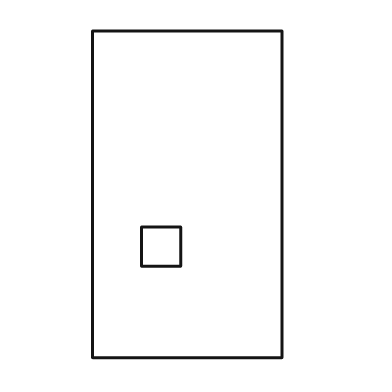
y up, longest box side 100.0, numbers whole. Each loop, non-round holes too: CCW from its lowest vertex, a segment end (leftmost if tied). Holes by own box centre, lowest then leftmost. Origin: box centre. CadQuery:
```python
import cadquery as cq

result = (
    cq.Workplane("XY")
    .moveTo(-29.0, -50.0)
    .lineTo(29.0, -50.0)
    .lineTo(29.0, 50.0)
    .lineTo(-29.0, 50.0)
    .close()
    .moveTo(-14.0, -22.0)
    .lineTo(-2.0, -22.0)
    .lineTo(-2.0, -10.0)
    .lineTo(-14.0, -10.0)
    .close()
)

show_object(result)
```